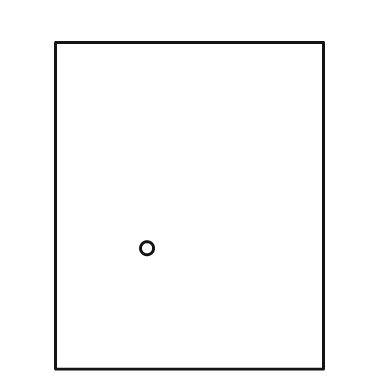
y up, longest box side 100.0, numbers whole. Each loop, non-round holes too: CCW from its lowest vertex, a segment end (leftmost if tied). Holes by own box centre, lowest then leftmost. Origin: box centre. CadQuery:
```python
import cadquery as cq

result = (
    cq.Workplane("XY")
    .moveTo(-41.0, -50.0)
    .lineTo(41.0, -50.0)
    .lineTo(41.0, 50.0)
    .lineTo(-41.0, 50.0)
    .close()
    .moveTo(-13.0, -13.0)
    .circle(2.0)
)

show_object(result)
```